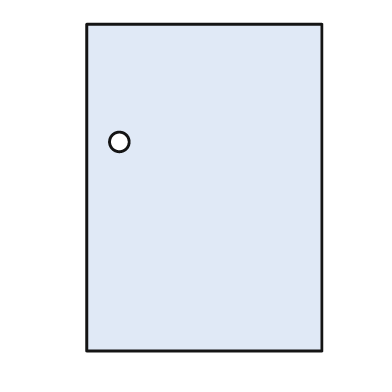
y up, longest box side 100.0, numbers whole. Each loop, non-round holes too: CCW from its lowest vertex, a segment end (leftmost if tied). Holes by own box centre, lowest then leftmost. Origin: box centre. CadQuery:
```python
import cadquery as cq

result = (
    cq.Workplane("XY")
    .moveTo(-36.0, -50.0)
    .lineTo(36.0, -50.0)
    .lineTo(36.0, 50.0)
    .lineTo(-36.0, 50.0)
    .close()
    .moveTo(-26.0, 14.0)
    .circle(3.0)
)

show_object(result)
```